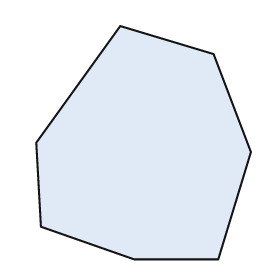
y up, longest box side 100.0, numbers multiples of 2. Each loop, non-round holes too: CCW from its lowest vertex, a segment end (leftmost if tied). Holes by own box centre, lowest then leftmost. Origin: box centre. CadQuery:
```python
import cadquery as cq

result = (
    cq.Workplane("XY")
    .moveTo(-4.0, -50.0)
    .lineTo(32.0, -50.0)
    .lineTo(46.0, -4.0)
    .lineTo(30.0, 38.0)
    .lineTo(-10.0, 50.0)
    .lineTo(-46.0, 0.0)
    .lineTo(-44.0, -36.0)
    .close()
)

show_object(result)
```